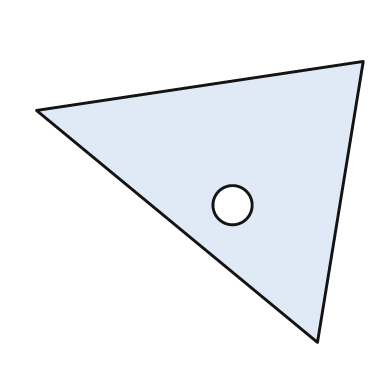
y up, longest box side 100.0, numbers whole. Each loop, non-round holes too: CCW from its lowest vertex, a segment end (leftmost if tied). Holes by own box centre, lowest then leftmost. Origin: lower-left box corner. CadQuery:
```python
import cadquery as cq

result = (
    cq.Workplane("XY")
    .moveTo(86.0, 0.0)
    .lineTo(100.0, 86.0)
    .lineTo(0.0, 71.0)
    .close()
    .moveTo(60.0, 42.0)
    .circle(6.0)
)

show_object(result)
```